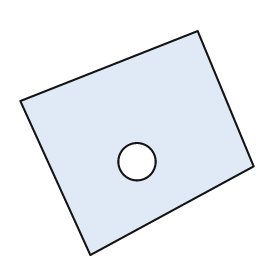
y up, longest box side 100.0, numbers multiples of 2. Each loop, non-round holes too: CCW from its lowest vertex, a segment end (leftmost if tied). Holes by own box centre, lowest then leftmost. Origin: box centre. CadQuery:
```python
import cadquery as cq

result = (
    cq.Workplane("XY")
    .moveTo(-20.0, -48.0)
    .lineTo(50.0, -10.0)
    .lineTo(26.0, 48.0)
    .lineTo(-50.0, 18.0)
    .close()
    .moveTo(0.0, -8.0)
    .circle(8.0)
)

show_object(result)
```